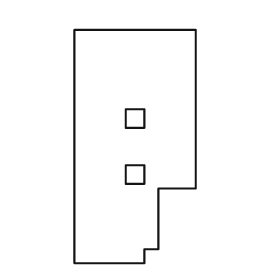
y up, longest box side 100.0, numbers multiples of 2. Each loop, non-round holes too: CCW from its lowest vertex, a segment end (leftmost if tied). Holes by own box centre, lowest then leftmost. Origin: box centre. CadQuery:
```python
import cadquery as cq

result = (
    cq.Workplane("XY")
    .moveTo(-26.0, -50.0)
    .lineTo(4.0, -50.0)
    .lineTo(4.0, -44.0)
    .lineTo(10.0, -44.0)
    .lineTo(10.0, -18.0)
    .lineTo(26.0, -18.0)
    .lineTo(26.0, 50.0)
    .lineTo(-26.0, 50.0)
    .close()
    .moveTo(-4.0, -16.0)
    .lineTo(4.0, -16.0)
    .lineTo(4.0, -8.0)
    .lineTo(-4.0, -8.0)
    .close()
    .moveTo(-4.0, 8.0)
    .lineTo(4.0, 8.0)
    .lineTo(4.0, 16.0)
    .lineTo(-4.0, 16.0)
    .close()
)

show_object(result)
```